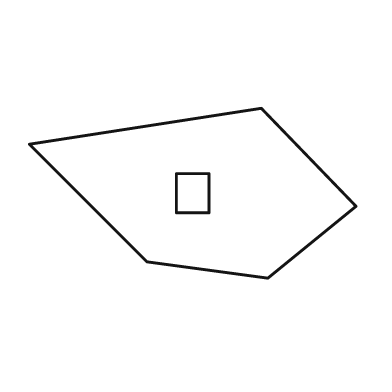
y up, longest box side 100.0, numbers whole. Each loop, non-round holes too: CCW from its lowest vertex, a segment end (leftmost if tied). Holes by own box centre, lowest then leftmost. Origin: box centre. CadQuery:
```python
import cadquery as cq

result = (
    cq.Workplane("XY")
    .moveTo(23.0, -26.0)
    .lineTo(50.0, -4.0)
    .lineTo(21.0, 26.0)
    .lineTo(-50.0, 15.0)
    .lineTo(-14.0, -21.0)
    .close()
    .moveTo(-5.0, -6.0)
    .lineTo(5.0, -6.0)
    .lineTo(5.0, 6.0)
    .lineTo(-5.0, 6.0)
    .close()
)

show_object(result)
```